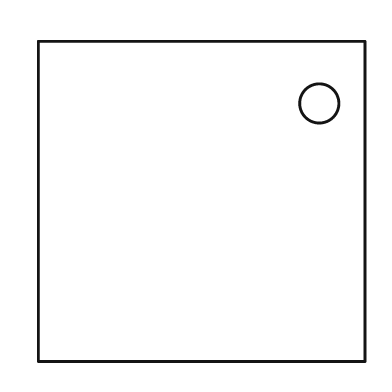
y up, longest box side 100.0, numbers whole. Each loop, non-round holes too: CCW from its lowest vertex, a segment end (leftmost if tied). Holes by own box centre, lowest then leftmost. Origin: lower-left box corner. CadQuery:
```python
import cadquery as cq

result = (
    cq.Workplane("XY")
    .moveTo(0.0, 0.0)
    .lineTo(100.0, 0.0)
    .lineTo(100.0, 98.0)
    .lineTo(0.0, 98.0)
    .close()
    .moveTo(86.0, 79.0)
    .circle(6.0)
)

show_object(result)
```